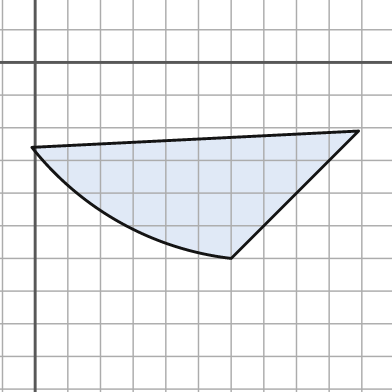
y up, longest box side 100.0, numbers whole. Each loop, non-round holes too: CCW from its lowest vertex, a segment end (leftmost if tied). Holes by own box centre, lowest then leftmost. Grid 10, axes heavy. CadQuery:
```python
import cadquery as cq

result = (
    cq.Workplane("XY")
    .moveTo(60.0, -60.0)
    .lineTo(99.0, -21.0)
    .lineTo(-1.0, -26.0)
    .threePointArc((26.0, -49.0), (60.0, -60.0))
    .close()
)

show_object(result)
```